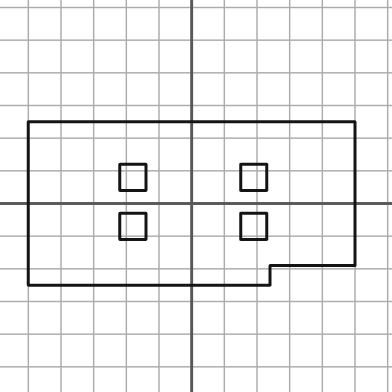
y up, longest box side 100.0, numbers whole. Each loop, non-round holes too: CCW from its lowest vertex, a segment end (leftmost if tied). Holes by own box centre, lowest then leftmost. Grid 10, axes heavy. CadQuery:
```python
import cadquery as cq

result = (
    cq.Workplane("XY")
    .moveTo(-50.0, -25.0)
    .lineTo(24.0, -25.0)
    .lineTo(24.0, -19.0)
    .lineTo(50.0, -19.0)
    .lineTo(50.0, 25.0)
    .lineTo(-50.0, 25.0)
    .close()
    .moveTo(-22.0, -11.0)
    .lineTo(-14.0, -11.0)
    .lineTo(-14.0, -3.0)
    .lineTo(-22.0, -3.0)
    .close()
    .moveTo(15.0, -11.0)
    .lineTo(23.0, -11.0)
    .lineTo(23.0, -3.0)
    .lineTo(15.0, -3.0)
    .close()
    .moveTo(-22.0, 4.0)
    .lineTo(-14.0, 4.0)
    .lineTo(-14.0, 12.0)
    .lineTo(-22.0, 12.0)
    .close()
    .moveTo(15.0, 4.0)
    .lineTo(23.0, 4.0)
    .lineTo(23.0, 12.0)
    .lineTo(15.0, 12.0)
    .close()
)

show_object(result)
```